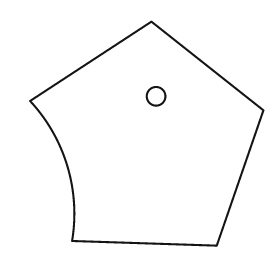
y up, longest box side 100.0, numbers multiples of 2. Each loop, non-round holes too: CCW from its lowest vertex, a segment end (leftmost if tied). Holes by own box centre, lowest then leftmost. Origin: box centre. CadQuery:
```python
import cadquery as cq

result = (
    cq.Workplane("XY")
    .moveTo(30.0, -48.0)
    .lineTo(50.0, 10.0)
    .lineTo(2.0, 48.0)
    .lineTo(-50.0, 14.0)
    .threePointArc((-34.0, -14.0), (-32.0, -46.0))
    .close()
    .moveTo(4.0, 16.0)
    .circle(4.0)
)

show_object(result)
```